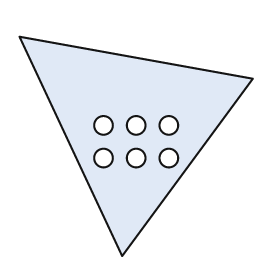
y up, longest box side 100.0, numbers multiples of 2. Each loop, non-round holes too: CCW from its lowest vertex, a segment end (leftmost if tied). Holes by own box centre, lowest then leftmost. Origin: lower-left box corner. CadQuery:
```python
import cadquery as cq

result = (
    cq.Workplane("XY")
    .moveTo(44.0, 0.0)
    .lineTo(100.0, 76.0)
    .lineTo(0.0, 94.0)
    .close()
    .moveTo(36.0, 42.0)
    .circle(4.0)
    .moveTo(50.0, 42.0)
    .circle(4.0)
    .moveTo(64.0, 42.0)
    .circle(4.0)
    .moveTo(36.0, 56.0)
    .circle(4.0)
    .moveTo(50.0, 56.0)
    .circle(4.0)
    .moveTo(64.0, 56.0)
    .circle(4.0)
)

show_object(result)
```